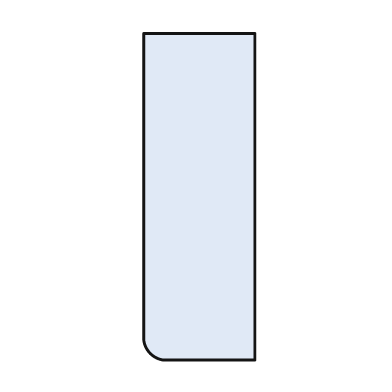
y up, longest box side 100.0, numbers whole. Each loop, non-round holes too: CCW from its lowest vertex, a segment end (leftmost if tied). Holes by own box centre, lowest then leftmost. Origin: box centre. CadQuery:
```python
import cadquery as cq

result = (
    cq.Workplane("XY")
    .moveTo(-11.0, -50.0)
    .lineTo(17.0, -50.0)
    .lineTo(17.0, 50.0)
    .lineTo(-17.0, 50.0)
    .lineTo(-17.0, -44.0)
    .threePointArc((-15.0, -48.0), (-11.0, -50.0))
    .close()
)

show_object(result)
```